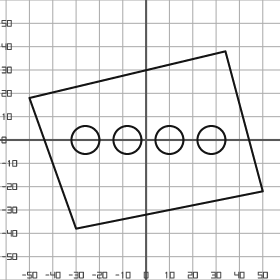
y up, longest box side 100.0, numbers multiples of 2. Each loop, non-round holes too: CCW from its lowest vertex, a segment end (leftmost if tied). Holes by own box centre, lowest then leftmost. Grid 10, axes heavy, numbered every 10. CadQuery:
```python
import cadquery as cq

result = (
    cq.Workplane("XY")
    .moveTo(-30.0, -38.0)
    .lineTo(50.0, -22.0)
    .lineTo(34.0, 38.0)
    .lineTo(-50.0, 18.0)
    .close()
    .moveTo(-26.0, 0.0)
    .circle(6.0)
    .moveTo(-8.0, 0.0)
    .circle(6.0)
    .moveTo(10.0, 0.0)
    .circle(6.0)
    .moveTo(28.0, 0.0)
    .circle(6.0)
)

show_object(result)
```